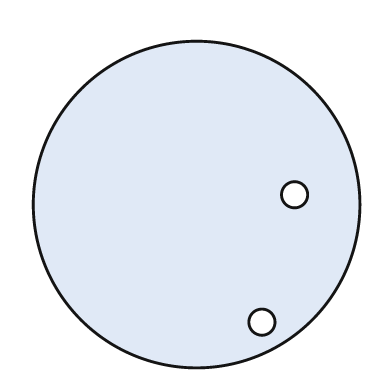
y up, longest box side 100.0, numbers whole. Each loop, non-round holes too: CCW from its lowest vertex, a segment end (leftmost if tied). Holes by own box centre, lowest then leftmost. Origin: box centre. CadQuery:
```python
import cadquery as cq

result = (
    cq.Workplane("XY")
    .moveTo(0.0, 0.0)
    .circle(50.0)
    .moveTo(20.0, -36.0)
    .circle(4.0)
    .moveTo(30.0, 3.0)
    .circle(4.0)
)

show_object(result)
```